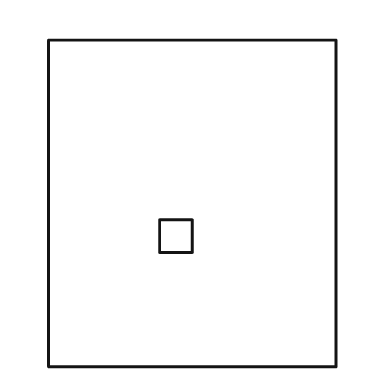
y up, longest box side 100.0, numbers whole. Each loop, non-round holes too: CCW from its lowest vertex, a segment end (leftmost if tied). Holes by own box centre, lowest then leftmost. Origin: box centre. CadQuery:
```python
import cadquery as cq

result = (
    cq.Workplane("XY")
    .moveTo(-44.0, -50.0)
    .lineTo(44.0, -50.0)
    .lineTo(44.0, 50.0)
    .lineTo(-44.0, 50.0)
    .close()
    .moveTo(-10.0, -15.0)
    .lineTo(0.0, -15.0)
    .lineTo(0.0, -5.0)
    .lineTo(-10.0, -5.0)
    .close()
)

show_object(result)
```